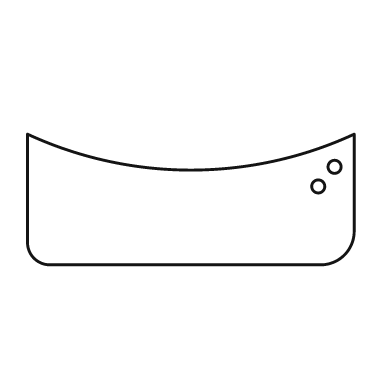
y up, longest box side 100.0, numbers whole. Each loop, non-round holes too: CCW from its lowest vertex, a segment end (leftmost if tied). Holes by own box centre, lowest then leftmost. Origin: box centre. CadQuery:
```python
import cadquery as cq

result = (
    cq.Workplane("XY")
    .moveTo(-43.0, -20.0)
    .lineTo(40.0, -20.0)
    .threePointArc((47.0, -17.0), (50.0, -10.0))
    .lineTo(50.0, 20.0)
    .threePointArc((0.0, 9.0), (-50.0, 20.0))
    .lineTo(-50.0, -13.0)
    .threePointArc((-48.0, -18.0), (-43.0, -20.0))
    .close()
    .moveTo(39.0, 4.0)
    .circle(2.0)
    .moveTo(44.0, 10.0)
    .circle(2.0)
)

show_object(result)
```